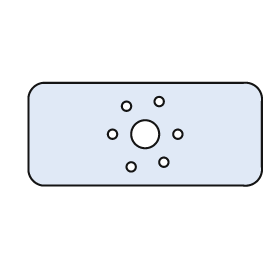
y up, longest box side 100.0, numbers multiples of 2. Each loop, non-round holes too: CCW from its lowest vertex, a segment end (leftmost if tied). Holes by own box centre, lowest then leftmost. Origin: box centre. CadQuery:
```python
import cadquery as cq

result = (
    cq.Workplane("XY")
    .moveTo(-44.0, -22.0)
    .lineTo(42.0, -22.0)
    .threePointArc((48.0, -20.0), (50.0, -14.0))
    .lineTo(50.0, 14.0)
    .threePointArc((48.0, 20.0), (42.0, 22.0))
    .lineTo(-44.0, 22.0)
    .threePointArc((-48.0, 20.0), (-50.0, 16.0))
    .lineTo(-50.0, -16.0)
    .threePointArc((-48.0, -20.0), (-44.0, -22.0))
    .close()
    .moveTo(-6.0, -14.0)
    .circle(2.0)
    .moveTo(8.0, -12.0)
    .circle(2.0)
    .moveTo(-14.0, 0.0)
    .circle(2.0)
    .moveTo(0.0, 0.0)
    .circle(6.0)
    .moveTo(14.0, 0.0)
    .circle(2.0)
    .moveTo(-8.0, 12.0)
    .circle(2.0)
    .moveTo(6.0, 14.0)
    .circle(2.0)
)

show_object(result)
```